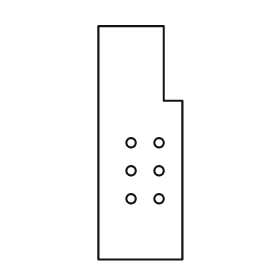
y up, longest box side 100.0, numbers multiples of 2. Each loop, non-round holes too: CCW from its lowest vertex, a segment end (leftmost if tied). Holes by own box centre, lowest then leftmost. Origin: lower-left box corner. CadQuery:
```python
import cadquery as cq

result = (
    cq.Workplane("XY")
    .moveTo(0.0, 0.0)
    .lineTo(36.0, 0.0)
    .lineTo(36.0, 68.0)
    .lineTo(28.0, 68.0)
    .lineTo(28.0, 100.0)
    .lineTo(0.0, 100.0)
    .close()
    .moveTo(14.0, 26.0)
    .circle(2.0)
    .moveTo(26.0, 26.0)
    .circle(2.0)
    .moveTo(14.0, 38.0)
    .circle(2.0)
    .moveTo(26.0, 38.0)
    .circle(2.0)
    .moveTo(14.0, 50.0)
    .circle(2.0)
    .moveTo(26.0, 50.0)
    .circle(2.0)
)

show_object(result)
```